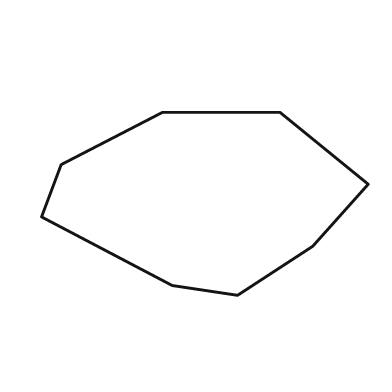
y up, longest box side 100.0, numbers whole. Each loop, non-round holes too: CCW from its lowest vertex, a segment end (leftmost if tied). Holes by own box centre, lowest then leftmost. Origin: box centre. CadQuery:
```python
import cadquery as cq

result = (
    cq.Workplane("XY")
    .moveTo(10.0, -28.0)
    .lineTo(33.0, -13.0)
    .lineTo(50.0, 6.0)
    .lineTo(23.0, 28.0)
    .lineTo(-13.0, 28.0)
    .lineTo(-44.0, 12.0)
    .lineTo(-50.0, -4.0)
    .lineTo(-10.0, -25.0)
    .close()
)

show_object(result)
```